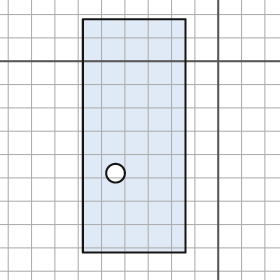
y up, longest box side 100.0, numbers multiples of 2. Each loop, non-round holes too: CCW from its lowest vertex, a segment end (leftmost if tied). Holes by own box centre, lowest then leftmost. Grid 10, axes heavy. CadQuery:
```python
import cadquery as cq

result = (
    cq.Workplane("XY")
    .moveTo(-58.0, -82.0)
    .lineTo(-14.0, -82.0)
    .lineTo(-14.0, 18.0)
    .lineTo(-58.0, 18.0)
    .close()
    .moveTo(-44.0, -48.0)
    .circle(4.0)
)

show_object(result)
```